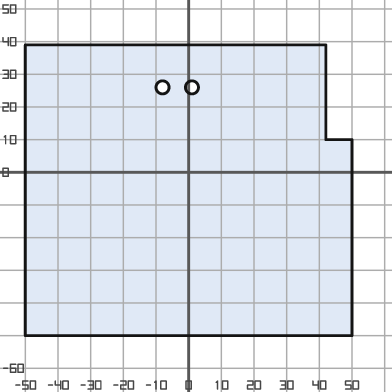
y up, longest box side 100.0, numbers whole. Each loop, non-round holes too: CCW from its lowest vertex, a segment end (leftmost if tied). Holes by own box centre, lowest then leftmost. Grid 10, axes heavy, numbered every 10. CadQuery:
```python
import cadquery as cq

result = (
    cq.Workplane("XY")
    .moveTo(-50.0, -50.0)
    .lineTo(50.0, -50.0)
    .lineTo(50.0, 10.0)
    .lineTo(42.0, 10.0)
    .lineTo(42.0, 39.0)
    .lineTo(-50.0, 39.0)
    .close()
    .moveTo(-8.0, 26.0)
    .circle(2.0)
    .moveTo(1.0, 26.0)
    .circle(2.0)
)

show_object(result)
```